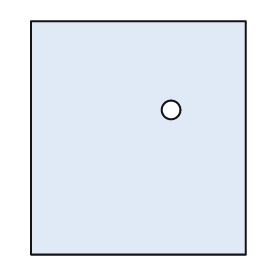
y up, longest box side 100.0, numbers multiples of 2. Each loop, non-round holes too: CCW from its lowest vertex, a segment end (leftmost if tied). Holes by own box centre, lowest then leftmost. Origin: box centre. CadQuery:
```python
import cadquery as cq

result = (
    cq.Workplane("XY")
    .moveTo(-46.0, -50.0)
    .lineTo(46.0, -50.0)
    .lineTo(46.0, 50.0)
    .lineTo(-46.0, 50.0)
    .close()
    .moveTo(14.0, 12.0)
    .circle(4.0)
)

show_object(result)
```